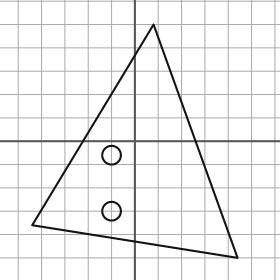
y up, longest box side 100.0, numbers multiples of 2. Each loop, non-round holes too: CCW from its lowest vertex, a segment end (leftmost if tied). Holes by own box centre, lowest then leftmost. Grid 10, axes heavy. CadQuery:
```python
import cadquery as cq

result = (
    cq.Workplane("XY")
    .moveTo(44.0, -50.0)
    .lineTo(8.0, 50.0)
    .lineTo(-44.0, -36.0)
    .close()
    .moveTo(-10.0, -30.0)
    .circle(4.0)
    .moveTo(-10.0, -6.0)
    .circle(4.0)
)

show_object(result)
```